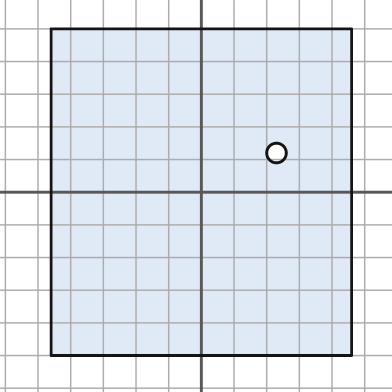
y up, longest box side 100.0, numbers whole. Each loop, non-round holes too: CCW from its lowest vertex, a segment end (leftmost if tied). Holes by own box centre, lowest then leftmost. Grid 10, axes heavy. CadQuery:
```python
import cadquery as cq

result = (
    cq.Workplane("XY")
    .moveTo(-46.0, -50.0)
    .lineTo(46.0, -50.0)
    .lineTo(46.0, 50.0)
    .lineTo(-46.0, 50.0)
    .close()
    .moveTo(23.0, 12.0)
    .circle(3.0)
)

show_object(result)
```